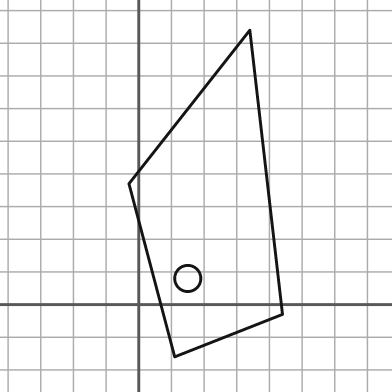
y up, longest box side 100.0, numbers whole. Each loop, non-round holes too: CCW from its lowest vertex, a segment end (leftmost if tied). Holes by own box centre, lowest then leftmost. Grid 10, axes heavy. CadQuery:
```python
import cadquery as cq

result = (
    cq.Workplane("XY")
    .moveTo(11.0, -16.0)
    .lineTo(44.0, -3.0)
    .lineTo(34.0, 84.0)
    .lineTo(-3.0, 37.0)
    .close()
    .moveTo(15.0, 8.0)
    .circle(4.0)
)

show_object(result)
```